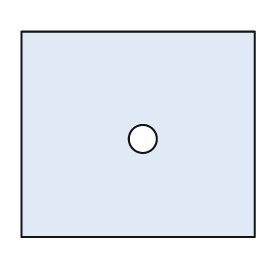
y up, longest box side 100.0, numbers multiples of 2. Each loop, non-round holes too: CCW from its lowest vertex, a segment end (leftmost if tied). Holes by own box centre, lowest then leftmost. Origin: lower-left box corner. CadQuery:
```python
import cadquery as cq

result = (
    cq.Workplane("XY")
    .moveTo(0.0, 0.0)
    .lineTo(100.0, 0.0)
    .lineTo(100.0, 88.0)
    .lineTo(0.0, 88.0)
    .close()
    .moveTo(52.0, 42.0)
    .circle(6.0)
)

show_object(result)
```